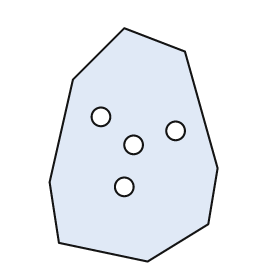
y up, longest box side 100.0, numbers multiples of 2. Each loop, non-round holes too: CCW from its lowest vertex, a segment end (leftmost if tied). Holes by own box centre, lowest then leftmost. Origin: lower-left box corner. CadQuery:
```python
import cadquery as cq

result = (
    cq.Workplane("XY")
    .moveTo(42.0, 0.0)
    .lineTo(68.0, 16.0)
    .lineTo(72.0, 40.0)
    .lineTo(58.0, 90.0)
    .lineTo(32.0, 100.0)
    .lineTo(10.0, 78.0)
    .lineTo(0.0, 34.0)
    .lineTo(4.0, 8.0)
    .close()
    .moveTo(32.0, 32.0)
    .circle(4.0)
    .moveTo(36.0, 50.0)
    .circle(4.0)
    .moveTo(54.0, 56.0)
    .circle(4.0)
    .moveTo(22.0, 62.0)
    .circle(4.0)
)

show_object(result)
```